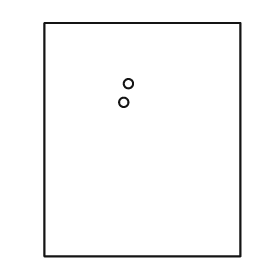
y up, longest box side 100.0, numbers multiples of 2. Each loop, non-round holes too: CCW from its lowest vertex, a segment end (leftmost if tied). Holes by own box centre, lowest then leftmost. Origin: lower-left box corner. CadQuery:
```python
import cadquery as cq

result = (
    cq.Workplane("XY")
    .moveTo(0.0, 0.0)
    .lineTo(84.0, 0.0)
    .lineTo(84.0, 100.0)
    .lineTo(0.0, 100.0)
    .close()
    .moveTo(34.0, 66.0)
    .circle(2.0)
    .moveTo(36.0, 74.0)
    .circle(2.0)
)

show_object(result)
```